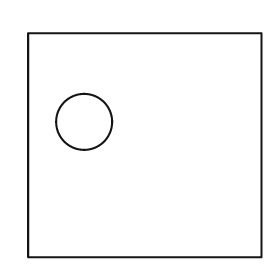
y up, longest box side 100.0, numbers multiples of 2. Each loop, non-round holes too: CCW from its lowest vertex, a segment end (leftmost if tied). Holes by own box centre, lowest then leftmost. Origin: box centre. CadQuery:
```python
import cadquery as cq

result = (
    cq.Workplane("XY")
    .moveTo(-50.0, -48.0)
    .lineTo(50.0, -48.0)
    .lineTo(50.0, 48.0)
    .lineTo(-50.0, 48.0)
    .close()
    .moveTo(-26.0, 10.0)
    .circle(12.0)
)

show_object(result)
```